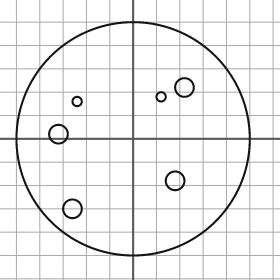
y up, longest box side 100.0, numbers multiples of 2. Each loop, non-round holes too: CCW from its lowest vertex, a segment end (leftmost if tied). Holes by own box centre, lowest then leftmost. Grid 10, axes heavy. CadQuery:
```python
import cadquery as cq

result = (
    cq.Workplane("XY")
    .moveTo(0.0, 0.0)
    .circle(50.0)
    .moveTo(-26.0, -30.0)
    .circle(4.0)
    .moveTo(18.0, -18.0)
    .circle(4.0)
    .moveTo(-32.0, 2.0)
    .circle(4.0)
    .moveTo(-24.0, 16.0)
    .circle(2.0)
    .moveTo(12.0, 18.0)
    .circle(2.0)
    .moveTo(22.0, 22.0)
    .circle(4.0)
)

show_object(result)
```